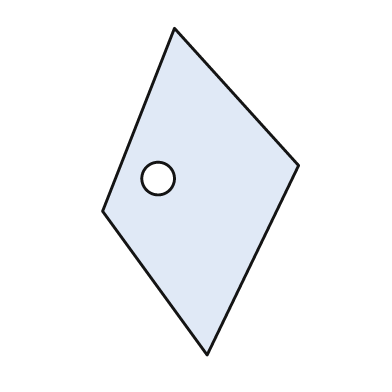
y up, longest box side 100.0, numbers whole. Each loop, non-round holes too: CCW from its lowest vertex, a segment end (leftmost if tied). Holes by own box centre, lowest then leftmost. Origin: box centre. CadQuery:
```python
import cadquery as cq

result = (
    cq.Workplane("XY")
    .moveTo(2.0, -50.0)
    .lineTo(30.0, 8.0)
    .lineTo(-8.0, 50.0)
    .lineTo(-30.0, -6.0)
    .close()
    .moveTo(-13.0, 4.0)
    .circle(5.0)
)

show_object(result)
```